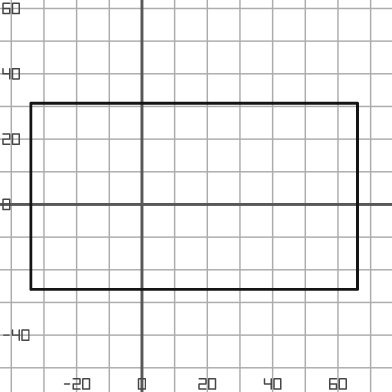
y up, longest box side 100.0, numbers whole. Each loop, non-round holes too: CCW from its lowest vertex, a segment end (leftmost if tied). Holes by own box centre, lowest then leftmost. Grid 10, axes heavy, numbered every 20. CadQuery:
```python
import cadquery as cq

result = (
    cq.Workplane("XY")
    .moveTo(-34.0, -26.0)
    .lineTo(66.0, -26.0)
    .lineTo(66.0, 31.0)
    .lineTo(-34.0, 31.0)
    .close()
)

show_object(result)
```